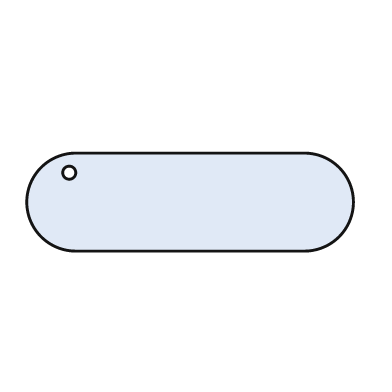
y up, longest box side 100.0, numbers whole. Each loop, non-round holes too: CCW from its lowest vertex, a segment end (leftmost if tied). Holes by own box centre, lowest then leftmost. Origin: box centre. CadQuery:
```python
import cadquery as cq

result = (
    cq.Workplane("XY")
    .moveTo(-35.0, -15.0)
    .lineTo(35.0, -15.0)
    .threePointArc((50.0, 0.0), (35.0, 15.0))
    .lineTo(-35.0, 15.0)
    .threePointArc((-50.0, 0.0), (-35.0, -15.0))
    .close()
    .moveTo(-37.0, 9.0)
    .circle(2.0)
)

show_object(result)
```